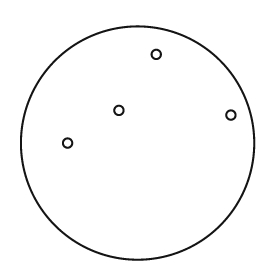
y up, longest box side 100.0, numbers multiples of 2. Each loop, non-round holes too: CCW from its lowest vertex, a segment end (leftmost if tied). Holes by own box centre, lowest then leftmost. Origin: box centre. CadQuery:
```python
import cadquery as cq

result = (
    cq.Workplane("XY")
    .moveTo(0.0, 0.0)
    .circle(50.0)
    .moveTo(-30.0, 0.0)
    .circle(2.0)
    .moveTo(40.0, 12.0)
    .circle(2.0)
    .moveTo(-8.0, 14.0)
    .circle(2.0)
    .moveTo(8.0, 38.0)
    .circle(2.0)
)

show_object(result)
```